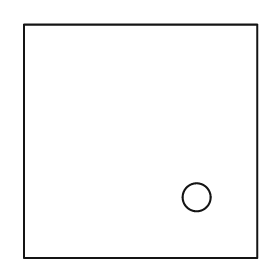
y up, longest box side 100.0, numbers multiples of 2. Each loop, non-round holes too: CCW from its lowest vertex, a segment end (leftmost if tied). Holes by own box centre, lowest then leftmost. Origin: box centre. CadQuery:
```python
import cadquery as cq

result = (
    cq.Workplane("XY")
    .moveTo(-50.0, -50.0)
    .lineTo(50.0, -50.0)
    .lineTo(50.0, 50.0)
    .lineTo(-50.0, 50.0)
    .close()
    .moveTo(24.0, -24.0)
    .circle(6.0)
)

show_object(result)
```